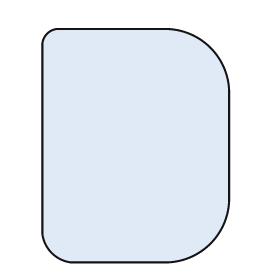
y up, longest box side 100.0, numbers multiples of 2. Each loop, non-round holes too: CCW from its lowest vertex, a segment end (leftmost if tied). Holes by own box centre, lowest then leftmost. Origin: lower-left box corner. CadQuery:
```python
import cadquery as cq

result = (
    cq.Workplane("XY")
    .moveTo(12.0, 0.0)
    .lineTo(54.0, 0.0)
    .threePointArc((72.0, 8.0), (80.0, 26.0))
    .lineTo(80.0, 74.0)
    .threePointArc((72.0, 92.0), (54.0, 100.0))
    .lineTo(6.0, 100.0)
    .threePointArc((2.0, 98.0), (0.0, 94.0))
    .lineTo(0.0, 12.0)
    .threePointArc((4.0, 4.0), (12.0, 0.0))
    .close()
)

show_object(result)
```